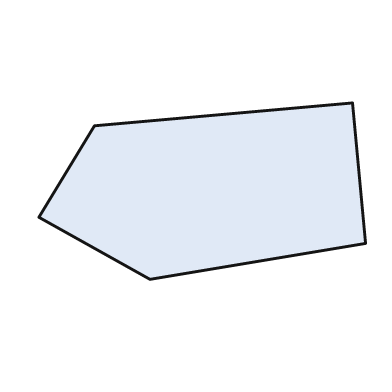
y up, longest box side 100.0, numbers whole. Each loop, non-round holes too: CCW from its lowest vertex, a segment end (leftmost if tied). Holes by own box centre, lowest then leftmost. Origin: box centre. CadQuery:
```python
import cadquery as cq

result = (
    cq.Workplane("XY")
    .moveTo(-16.0, -27.0)
    .lineTo(50.0, -16.0)
    .lineTo(46.0, 27.0)
    .lineTo(-33.0, 20.0)
    .lineTo(-50.0, -8.0)
    .close()
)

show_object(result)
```